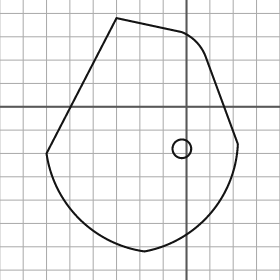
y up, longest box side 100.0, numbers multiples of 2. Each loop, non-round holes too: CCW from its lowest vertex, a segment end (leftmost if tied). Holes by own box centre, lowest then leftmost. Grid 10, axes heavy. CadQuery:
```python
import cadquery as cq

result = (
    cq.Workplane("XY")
    .moveTo(-18.0, -62.0)
    .threePointArc((10.0, -46.0), (22.0, -16.0))
    .lineTo(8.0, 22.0)
    .threePointArc((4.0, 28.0), (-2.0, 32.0))
    .lineTo(-30.0, 38.0)
    .lineTo(-60.0, -20.0)
    .threePointArc((-46.0, -48.0), (-18.0, -62.0))
    .close()
    .moveTo(-2.0, -18.0)
    .circle(4.0)
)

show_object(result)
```